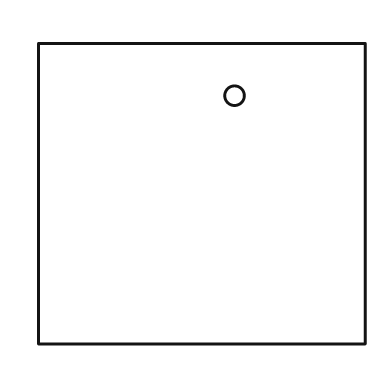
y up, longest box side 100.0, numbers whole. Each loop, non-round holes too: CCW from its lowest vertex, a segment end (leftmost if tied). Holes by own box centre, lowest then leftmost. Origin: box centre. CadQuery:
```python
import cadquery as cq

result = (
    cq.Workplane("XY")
    .moveTo(-50.0, -46.0)
    .lineTo(50.0, -46.0)
    .lineTo(50.0, 46.0)
    .lineTo(-50.0, 46.0)
    .close()
    .moveTo(10.0, 30.0)
    .circle(3.0)
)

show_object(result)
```